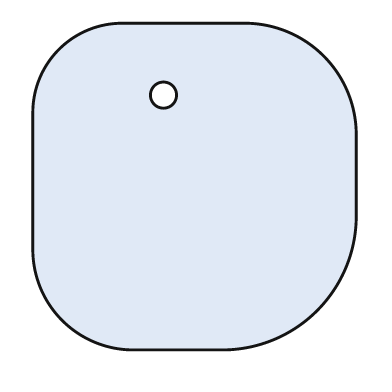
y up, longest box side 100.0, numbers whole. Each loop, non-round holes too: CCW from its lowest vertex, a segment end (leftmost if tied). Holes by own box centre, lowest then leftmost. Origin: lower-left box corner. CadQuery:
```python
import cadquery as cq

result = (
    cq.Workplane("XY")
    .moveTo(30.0, 0.0)
    .lineTo(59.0, 0.0)
    .threePointArc((87.0, 12.0), (99.0, 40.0))
    .lineTo(99.0, 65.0)
    .threePointArc((89.0, 90.0), (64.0, 100.0))
    .lineTo(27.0, 100.0)
    .threePointArc((8.0, 92.0), (0.0, 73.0))
    .lineTo(0.0, 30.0)
    .threePointArc((9.0, 9.0), (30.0, 0.0))
    .close()
    .moveTo(40.0, 78.0)
    .circle(4.0)
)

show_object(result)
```